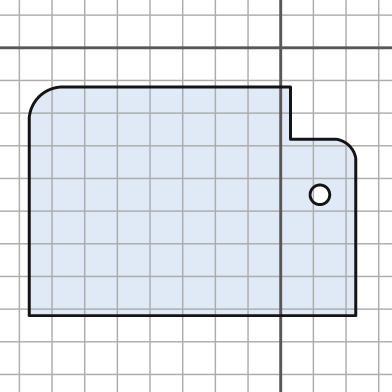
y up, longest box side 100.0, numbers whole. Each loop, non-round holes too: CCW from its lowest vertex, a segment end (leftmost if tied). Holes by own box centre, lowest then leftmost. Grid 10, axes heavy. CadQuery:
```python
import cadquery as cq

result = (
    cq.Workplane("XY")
    .moveTo(-77.0, -82.0)
    .lineTo(23.0, -82.0)
    .lineTo(23.0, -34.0)
    .threePointArc((21.0, -30.0), (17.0, -28.0))
    .lineTo(3.0, -28.0)
    .lineTo(3.0, -12.0)
    .lineTo(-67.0, -12.0)
    .threePointArc((-74.0, -15.0), (-77.0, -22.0))
    .close()
    .moveTo(12.0, -45.0)
    .circle(3.0)
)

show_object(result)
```